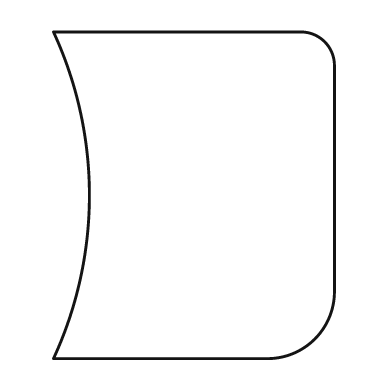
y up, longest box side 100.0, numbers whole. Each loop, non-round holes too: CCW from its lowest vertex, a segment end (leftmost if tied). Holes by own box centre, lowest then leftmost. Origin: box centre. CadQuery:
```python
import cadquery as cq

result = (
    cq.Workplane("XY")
    .moveTo(-43.0, -50.0)
    .lineTo(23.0, -50.0)
    .threePointArc((37.0, -44.0), (43.0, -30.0))
    .lineTo(43.0, 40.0)
    .threePointArc((40.0, 47.0), (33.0, 50.0))
    .lineTo(-43.0, 50.0)
    .threePointArc((-32.0, 0.0), (-43.0, -50.0))
    .close()
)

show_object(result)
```